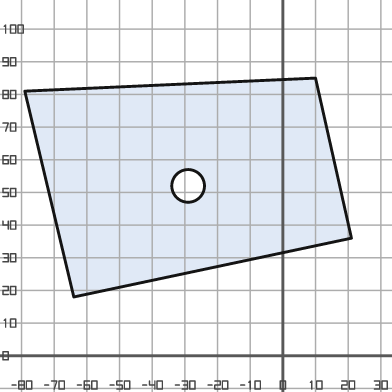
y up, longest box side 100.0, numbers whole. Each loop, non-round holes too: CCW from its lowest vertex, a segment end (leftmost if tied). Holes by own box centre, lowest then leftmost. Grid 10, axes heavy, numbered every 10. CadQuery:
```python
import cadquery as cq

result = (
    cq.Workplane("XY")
    .moveTo(-64.0, 18.0)
    .lineTo(21.0, 36.0)
    .lineTo(10.0, 85.0)
    .lineTo(-79.0, 81.0)
    .close()
    .moveTo(-29.0, 52.0)
    .circle(5.0)
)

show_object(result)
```